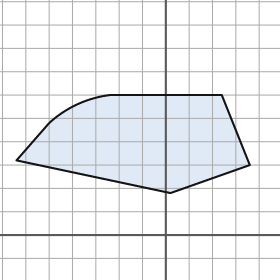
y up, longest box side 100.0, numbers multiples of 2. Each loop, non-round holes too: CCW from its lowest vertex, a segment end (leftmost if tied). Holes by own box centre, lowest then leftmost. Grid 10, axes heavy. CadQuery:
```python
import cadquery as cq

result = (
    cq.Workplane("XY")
    .moveTo(2.0, 18.0)
    .lineTo(36.0, 30.0)
    .lineTo(24.0, 60.0)
    .lineTo(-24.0, 60.0)
    .threePointArc((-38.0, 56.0), (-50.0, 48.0))
    .lineTo(-64.0, 32.0)
    .close()
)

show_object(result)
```